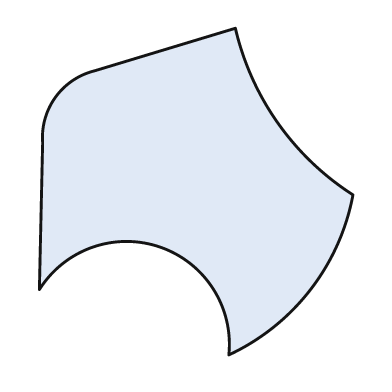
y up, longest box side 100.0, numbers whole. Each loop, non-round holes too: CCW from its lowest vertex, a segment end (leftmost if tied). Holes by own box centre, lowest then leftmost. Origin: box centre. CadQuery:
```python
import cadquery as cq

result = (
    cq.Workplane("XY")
    .moveTo(10.0, -50.0)
    .threePointArc((35.0, -30.0), (48.0, -1.0))
    .threePointArc((25.0, 21.0), (12.0, 50.0))
    .lineTo(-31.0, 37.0)
    .threePointArc((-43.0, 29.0), (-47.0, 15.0))
    .lineTo(-48.0, -30.0)
    .threePointArc((-11.0, -17.0), (10.0, -50.0))
    .close()
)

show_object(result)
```